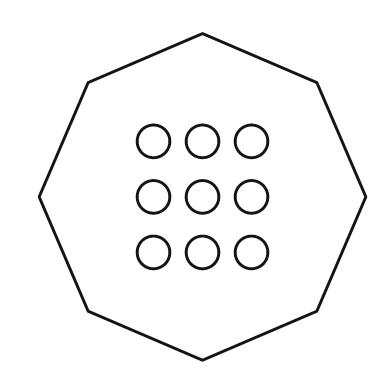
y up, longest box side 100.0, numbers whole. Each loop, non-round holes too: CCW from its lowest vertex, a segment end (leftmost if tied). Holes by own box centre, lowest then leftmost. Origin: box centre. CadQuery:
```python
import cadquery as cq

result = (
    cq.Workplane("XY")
    .moveTo(0.0, -50.0)
    .lineTo(35.0, -35.0)
    .lineTo(50.0, 0.0)
    .lineTo(35.0, 35.0)
    .lineTo(0.0, 50.0)
    .lineTo(-35.0, 35.0)
    .lineTo(-50.0, 0.0)
    .lineTo(-35.0, -35.0)
    .close()
    .moveTo(-15.0, -17.0)
    .circle(5.0)
    .moveTo(0.0, -17.0)
    .circle(5.0)
    .moveTo(15.0, -17.0)
    .circle(5.0)
    .moveTo(-15.0, 0.0)
    .circle(5.0)
    .moveTo(0.0, 0.0)
    .circle(5.0)
    .moveTo(15.0, 0.0)
    .circle(5.0)
    .moveTo(-15.0, 17.0)
    .circle(5.0)
    .moveTo(0.0, 17.0)
    .circle(5.0)
    .moveTo(15.0, 17.0)
    .circle(5.0)
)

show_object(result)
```